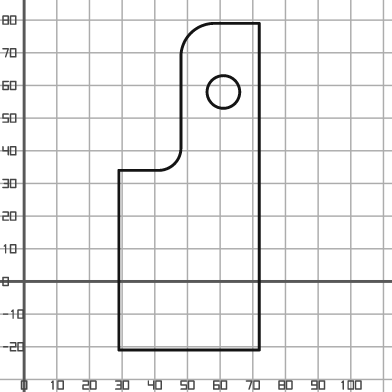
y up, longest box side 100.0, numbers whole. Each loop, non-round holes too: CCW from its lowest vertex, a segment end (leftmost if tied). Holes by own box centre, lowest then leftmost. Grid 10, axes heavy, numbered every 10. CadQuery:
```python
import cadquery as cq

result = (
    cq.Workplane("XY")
    .moveTo(29.0, -21.0)
    .lineTo(72.0, -21.0)
    .lineTo(72.0, 79.0)
    .lineTo(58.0, 79.0)
    .threePointArc((51.0, 76.0), (48.0, 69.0))
    .lineTo(48.0, 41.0)
    .threePointArc((46.0, 36.0), (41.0, 34.0))
    .lineTo(29.0, 34.0)
    .close()
    .moveTo(61.0, 58.0)
    .circle(5.0)
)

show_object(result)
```